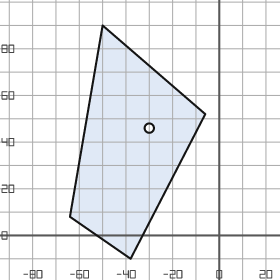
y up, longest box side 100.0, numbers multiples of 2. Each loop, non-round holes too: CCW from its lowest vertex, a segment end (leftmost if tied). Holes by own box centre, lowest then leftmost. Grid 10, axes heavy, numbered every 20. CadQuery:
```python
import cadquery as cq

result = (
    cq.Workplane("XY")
    .moveTo(-38.0, -10.0)
    .lineTo(-6.0, 52.0)
    .lineTo(-50.0, 90.0)
    .lineTo(-64.0, 8.0)
    .close()
    .moveTo(-30.0, 46.0)
    .circle(2.0)
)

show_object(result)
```